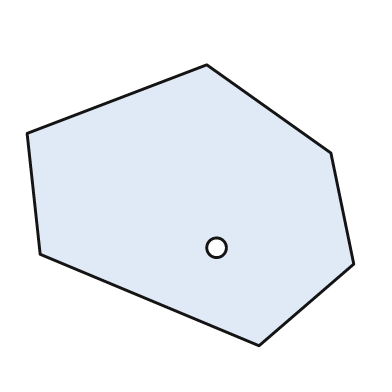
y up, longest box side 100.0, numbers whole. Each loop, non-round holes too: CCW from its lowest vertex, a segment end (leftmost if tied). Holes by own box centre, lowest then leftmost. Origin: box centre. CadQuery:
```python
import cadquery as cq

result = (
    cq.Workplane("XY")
    .moveTo(21.0, -43.0)
    .lineTo(50.0, -18.0)
    .lineTo(43.0, 16.0)
    .lineTo(5.0, 43.0)
    .lineTo(-50.0, 22.0)
    .lineTo(-46.0, -15.0)
    .close()
    .moveTo(8.0, -13.0)
    .circle(3.0)
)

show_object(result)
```